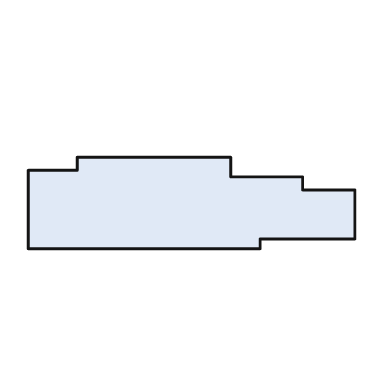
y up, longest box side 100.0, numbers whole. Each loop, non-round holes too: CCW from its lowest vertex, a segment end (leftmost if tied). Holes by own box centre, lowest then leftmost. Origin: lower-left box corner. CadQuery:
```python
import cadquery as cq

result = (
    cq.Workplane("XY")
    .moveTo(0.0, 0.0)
    .lineTo(71.0, 0.0)
    .lineTo(71.0, 3.0)
    .lineTo(100.0, 3.0)
    .lineTo(100.0, 18.0)
    .lineTo(84.0, 18.0)
    .lineTo(84.0, 22.0)
    .lineTo(62.0, 22.0)
    .lineTo(62.0, 28.0)
    .lineTo(15.0, 28.0)
    .lineTo(15.0, 24.0)
    .lineTo(0.0, 24.0)
    .close()
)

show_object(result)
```